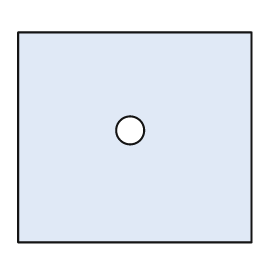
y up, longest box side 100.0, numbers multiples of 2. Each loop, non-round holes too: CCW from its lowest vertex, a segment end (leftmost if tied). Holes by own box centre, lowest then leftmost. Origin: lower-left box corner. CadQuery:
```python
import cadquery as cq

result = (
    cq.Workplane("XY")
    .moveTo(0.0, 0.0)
    .lineTo(100.0, 0.0)
    .lineTo(100.0, 90.0)
    .lineTo(0.0, 90.0)
    .close()
    .moveTo(48.0, 48.0)
    .circle(6.0)
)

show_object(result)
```